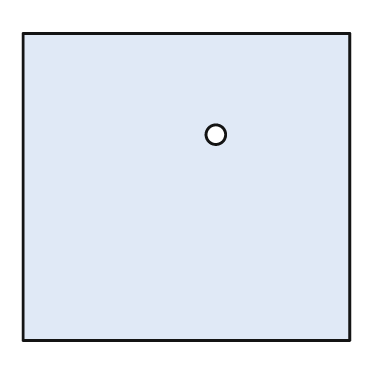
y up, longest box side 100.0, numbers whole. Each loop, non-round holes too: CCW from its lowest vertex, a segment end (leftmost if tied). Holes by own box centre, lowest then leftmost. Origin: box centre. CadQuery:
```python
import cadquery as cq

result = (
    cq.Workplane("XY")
    .moveTo(-50.0, -47.0)
    .lineTo(50.0, -47.0)
    .lineTo(50.0, 47.0)
    .lineTo(-50.0, 47.0)
    .close()
    .moveTo(9.0, 16.0)
    .circle(3.0)
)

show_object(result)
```